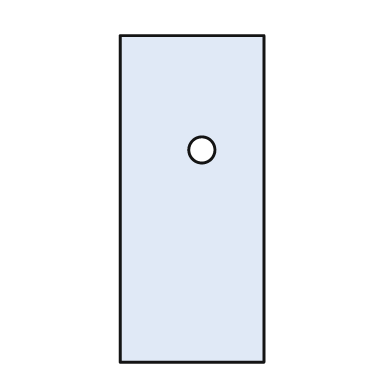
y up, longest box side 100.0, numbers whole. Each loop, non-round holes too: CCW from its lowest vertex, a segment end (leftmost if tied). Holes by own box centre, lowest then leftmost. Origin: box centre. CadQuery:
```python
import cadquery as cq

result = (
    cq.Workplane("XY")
    .moveTo(-22.0, -50.0)
    .lineTo(22.0, -50.0)
    .lineTo(22.0, 50.0)
    .lineTo(-22.0, 50.0)
    .close()
    .moveTo(3.0, 15.0)
    .circle(4.0)
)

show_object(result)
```